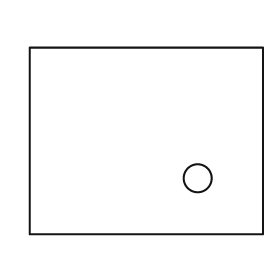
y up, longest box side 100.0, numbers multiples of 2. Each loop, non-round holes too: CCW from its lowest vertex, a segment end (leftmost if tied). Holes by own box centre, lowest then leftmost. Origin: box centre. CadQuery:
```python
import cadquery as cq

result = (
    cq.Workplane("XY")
    .moveTo(-50.0, -40.0)
    .lineTo(50.0, -40.0)
    .lineTo(50.0, 40.0)
    .lineTo(-50.0, 40.0)
    .close()
    .moveTo(22.0, -16.0)
    .circle(6.0)
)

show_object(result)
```